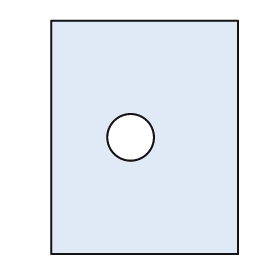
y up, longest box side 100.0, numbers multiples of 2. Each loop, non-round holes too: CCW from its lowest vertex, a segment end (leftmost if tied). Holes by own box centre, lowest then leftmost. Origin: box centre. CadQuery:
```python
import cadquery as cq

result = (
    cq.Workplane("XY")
    .moveTo(-40.0, -50.0)
    .lineTo(40.0, -50.0)
    .lineTo(40.0, 50.0)
    .lineTo(-40.0, 50.0)
    .close()
    .moveTo(-6.0, 0.0)
    .circle(10.0)
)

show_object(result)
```